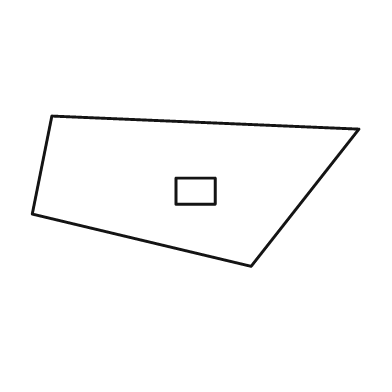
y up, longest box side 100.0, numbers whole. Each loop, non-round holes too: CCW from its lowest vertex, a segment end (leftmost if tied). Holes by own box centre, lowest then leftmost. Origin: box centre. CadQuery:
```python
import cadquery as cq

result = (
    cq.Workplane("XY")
    .moveTo(17.0, -23.0)
    .lineTo(50.0, 19.0)
    .lineTo(-44.0, 23.0)
    .lineTo(-50.0, -7.0)
    .close()
    .moveTo(-6.0, -4.0)
    .lineTo(6.0, -4.0)
    .lineTo(6.0, 4.0)
    .lineTo(-6.0, 4.0)
    .close()
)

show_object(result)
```